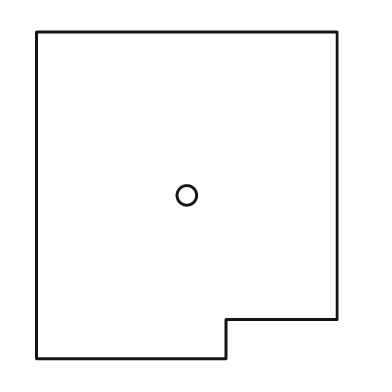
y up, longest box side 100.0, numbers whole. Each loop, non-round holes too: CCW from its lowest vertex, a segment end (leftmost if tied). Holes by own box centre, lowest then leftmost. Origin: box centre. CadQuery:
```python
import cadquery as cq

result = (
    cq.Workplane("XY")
    .moveTo(-46.0, -50.0)
    .lineTo(12.0, -50.0)
    .lineTo(12.0, -38.0)
    .lineTo(46.0, -38.0)
    .lineTo(46.0, 50.0)
    .lineTo(-46.0, 50.0)
    .close()
    .moveTo(0.0, 0.0)
    .circle(3.0)
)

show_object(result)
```